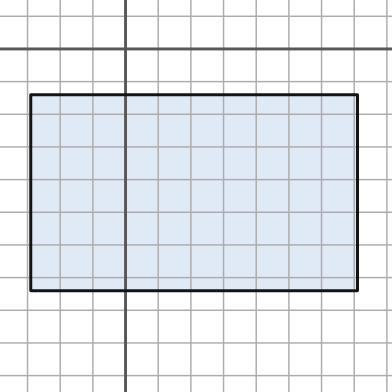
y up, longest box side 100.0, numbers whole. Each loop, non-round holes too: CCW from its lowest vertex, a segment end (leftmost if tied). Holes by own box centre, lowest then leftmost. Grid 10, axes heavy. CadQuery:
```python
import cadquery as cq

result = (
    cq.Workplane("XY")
    .moveTo(-29.0, -74.0)
    .lineTo(71.0, -74.0)
    .lineTo(71.0, -14.0)
    .lineTo(-29.0, -14.0)
    .close()
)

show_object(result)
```